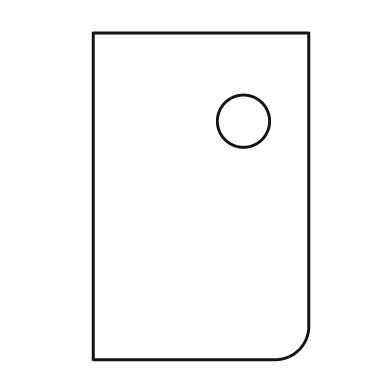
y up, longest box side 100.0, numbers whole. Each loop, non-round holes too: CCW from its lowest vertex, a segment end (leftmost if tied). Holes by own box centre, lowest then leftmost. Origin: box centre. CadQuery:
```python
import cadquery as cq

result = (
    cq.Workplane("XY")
    .moveTo(-33.0, -50.0)
    .lineTo(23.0, -50.0)
    .threePointArc((30.0, -47.0), (33.0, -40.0))
    .lineTo(33.0, 50.0)
    .lineTo(-33.0, 50.0)
    .close()
    .moveTo(13.0, 23.0)
    .circle(8.0)
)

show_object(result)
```